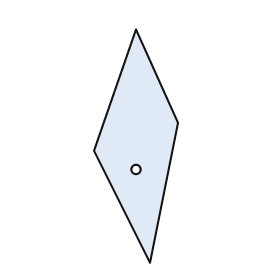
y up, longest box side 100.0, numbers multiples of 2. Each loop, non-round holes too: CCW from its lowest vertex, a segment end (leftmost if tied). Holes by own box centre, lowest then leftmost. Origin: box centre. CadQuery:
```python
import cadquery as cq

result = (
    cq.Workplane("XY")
    .moveTo(6.0, -50.0)
    .lineTo(18.0, 10.0)
    .lineTo(0.0, 50.0)
    .lineTo(-18.0, -2.0)
    .close()
    .moveTo(0.0, -10.0)
    .circle(2.0)
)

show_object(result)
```